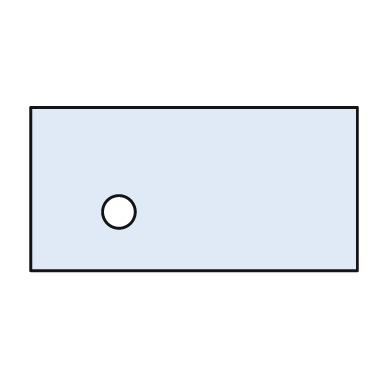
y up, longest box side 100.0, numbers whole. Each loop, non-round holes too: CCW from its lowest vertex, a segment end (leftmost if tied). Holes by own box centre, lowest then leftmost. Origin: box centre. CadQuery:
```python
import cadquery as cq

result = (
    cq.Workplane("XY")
    .moveTo(-50.0, -25.0)
    .lineTo(50.0, -25.0)
    .lineTo(50.0, 25.0)
    .lineTo(-50.0, 25.0)
    .close()
    .moveTo(-23.0, -7.0)
    .circle(5.0)
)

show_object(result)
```